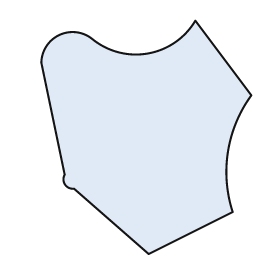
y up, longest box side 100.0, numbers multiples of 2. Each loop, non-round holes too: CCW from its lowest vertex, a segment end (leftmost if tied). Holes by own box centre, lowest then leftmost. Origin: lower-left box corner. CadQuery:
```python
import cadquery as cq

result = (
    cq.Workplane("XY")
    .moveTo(46.0, 0.0)
    .lineTo(82.0, 18.0)
    .threePointArc((80.0, 44.0), (90.0, 68.0))
    .lineTo(66.0, 100.0)
    .threePointArc((46.0, 86.0), (22.0, 92.0))
    .threePointArc((8.0, 94.0), (0.0, 82.0))
    .lineTo(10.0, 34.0)
    .threePointArc((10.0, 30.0), (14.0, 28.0))
    .close()
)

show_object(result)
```